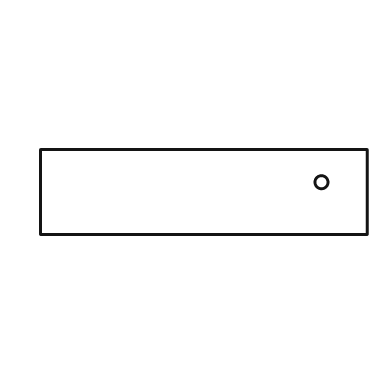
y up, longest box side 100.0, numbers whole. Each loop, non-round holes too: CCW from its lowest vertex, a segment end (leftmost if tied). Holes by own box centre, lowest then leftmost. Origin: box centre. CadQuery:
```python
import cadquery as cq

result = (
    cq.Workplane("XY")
    .moveTo(-50.0, -13.0)
    .lineTo(50.0, -13.0)
    .lineTo(50.0, 13.0)
    .lineTo(-50.0, 13.0)
    .close()
    .moveTo(36.0, 3.0)
    .circle(2.0)
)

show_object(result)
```